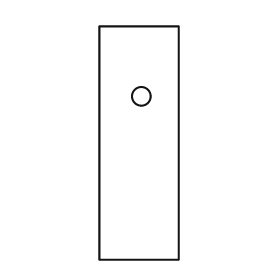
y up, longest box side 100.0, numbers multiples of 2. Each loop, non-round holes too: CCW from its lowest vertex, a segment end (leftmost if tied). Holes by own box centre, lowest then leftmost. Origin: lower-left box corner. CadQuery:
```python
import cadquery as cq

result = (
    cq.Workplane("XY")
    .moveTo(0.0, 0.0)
    .lineTo(34.0, 0.0)
    .lineTo(34.0, 100.0)
    .lineTo(0.0, 100.0)
    .close()
    .moveTo(18.0, 70.0)
    .circle(4.0)
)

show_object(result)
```